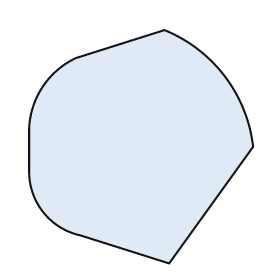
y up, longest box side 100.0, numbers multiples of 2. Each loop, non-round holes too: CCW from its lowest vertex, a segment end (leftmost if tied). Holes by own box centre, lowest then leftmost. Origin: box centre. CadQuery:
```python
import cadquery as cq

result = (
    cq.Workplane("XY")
    .moveTo(12.0, -50.0)
    .lineTo(48.0, 0.0)
    .threePointArc((36.0, 30.0), (10.0, 50.0))
    .lineTo(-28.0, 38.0)
    .threePointArc((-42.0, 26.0), (-48.0, 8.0))
    .lineTo(-48.0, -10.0)
    .threePointArc((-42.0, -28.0), (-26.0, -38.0))
    .close()
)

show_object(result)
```